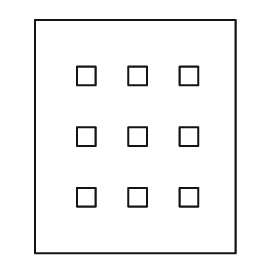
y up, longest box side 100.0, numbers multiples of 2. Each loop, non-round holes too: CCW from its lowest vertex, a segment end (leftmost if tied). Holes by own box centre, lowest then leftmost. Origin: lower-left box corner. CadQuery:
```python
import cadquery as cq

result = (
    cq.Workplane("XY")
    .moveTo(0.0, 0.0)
    .lineTo(86.0, 0.0)
    .lineTo(86.0, 100.0)
    .lineTo(0.0, 100.0)
    .close()
    .moveTo(18.0, 20.0)
    .lineTo(26.0, 20.0)
    .lineTo(26.0, 28.0)
    .lineTo(18.0, 28.0)
    .close()
    .moveTo(40.0, 20.0)
    .lineTo(48.0, 20.0)
    .lineTo(48.0, 28.0)
    .lineTo(40.0, 28.0)
    .close()
    .moveTo(62.0, 20.0)
    .lineTo(70.0, 20.0)
    .lineTo(70.0, 28.0)
    .lineTo(62.0, 28.0)
    .close()
    .moveTo(18.0, 46.0)
    .lineTo(26.0, 46.0)
    .lineTo(26.0, 54.0)
    .lineTo(18.0, 54.0)
    .close()
    .moveTo(40.0, 46.0)
    .lineTo(48.0, 46.0)
    .lineTo(48.0, 54.0)
    .lineTo(40.0, 54.0)
    .close()
    .moveTo(62.0, 46.0)
    .lineTo(70.0, 46.0)
    .lineTo(70.0, 54.0)
    .lineTo(62.0, 54.0)
    .close()
    .moveTo(18.0, 72.0)
    .lineTo(26.0, 72.0)
    .lineTo(26.0, 80.0)
    .lineTo(18.0, 80.0)
    .close()
    .moveTo(40.0, 72.0)
    .lineTo(48.0, 72.0)
    .lineTo(48.0, 80.0)
    .lineTo(40.0, 80.0)
    .close()
    .moveTo(62.0, 72.0)
    .lineTo(70.0, 72.0)
    .lineTo(70.0, 80.0)
    .lineTo(62.0, 80.0)
    .close()
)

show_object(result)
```